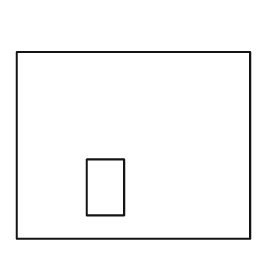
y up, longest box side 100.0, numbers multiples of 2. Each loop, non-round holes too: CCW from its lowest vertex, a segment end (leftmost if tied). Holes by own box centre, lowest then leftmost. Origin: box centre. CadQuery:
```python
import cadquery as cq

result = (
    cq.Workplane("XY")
    .moveTo(-50.0, -40.0)
    .lineTo(50.0, -40.0)
    .lineTo(50.0, 40.0)
    .lineTo(-50.0, 40.0)
    .close()
    .moveTo(-20.0, -30.0)
    .lineTo(-4.0, -30.0)
    .lineTo(-4.0, -6.0)
    .lineTo(-20.0, -6.0)
    .close()
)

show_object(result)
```